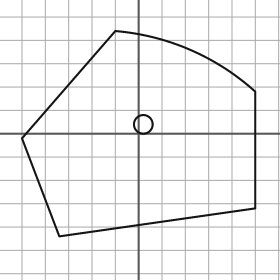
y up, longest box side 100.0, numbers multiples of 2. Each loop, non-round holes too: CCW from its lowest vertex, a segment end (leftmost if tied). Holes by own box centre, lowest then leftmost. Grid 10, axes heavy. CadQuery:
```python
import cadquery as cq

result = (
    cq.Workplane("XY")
    .moveTo(-34.0, -44.0)
    .lineTo(50.0, -32.0)
    .lineTo(50.0, 18.0)
    .threePointArc((22.0, 36.0), (-10.0, 44.0))
    .lineTo(-50.0, -2.0)
    .close()
    .moveTo(2.0, 4.0)
    .circle(4.0)
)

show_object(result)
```